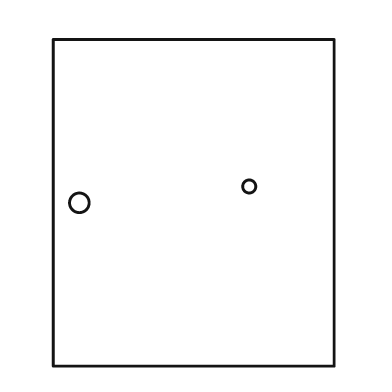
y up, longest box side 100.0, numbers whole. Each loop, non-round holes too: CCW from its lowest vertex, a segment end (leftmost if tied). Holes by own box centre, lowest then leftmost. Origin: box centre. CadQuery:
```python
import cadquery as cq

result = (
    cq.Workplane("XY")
    .moveTo(-43.0, -50.0)
    .lineTo(43.0, -50.0)
    .lineTo(43.0, 50.0)
    .lineTo(-43.0, 50.0)
    .close()
    .moveTo(-35.0, 0.0)
    .circle(3.0)
    .moveTo(17.0, 5.0)
    .circle(2.0)
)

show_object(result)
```